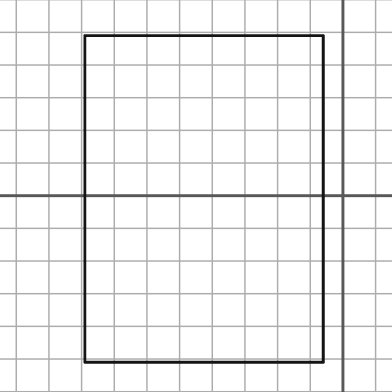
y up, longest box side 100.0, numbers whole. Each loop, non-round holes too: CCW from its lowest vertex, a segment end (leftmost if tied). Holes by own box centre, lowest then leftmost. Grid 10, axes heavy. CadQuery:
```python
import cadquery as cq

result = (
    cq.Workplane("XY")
    .moveTo(-79.0, -51.0)
    .lineTo(-6.0, -51.0)
    .lineTo(-6.0, 49.0)
    .lineTo(-79.0, 49.0)
    .close()
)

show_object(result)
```